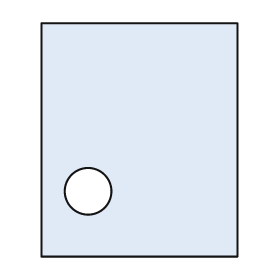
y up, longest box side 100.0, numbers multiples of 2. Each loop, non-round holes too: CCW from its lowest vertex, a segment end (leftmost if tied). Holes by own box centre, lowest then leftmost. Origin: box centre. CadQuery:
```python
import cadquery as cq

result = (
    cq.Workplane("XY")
    .moveTo(-42.0, -50.0)
    .lineTo(42.0, -50.0)
    .lineTo(42.0, 50.0)
    .lineTo(-42.0, 50.0)
    .close()
    .moveTo(-22.0, -22.0)
    .circle(10.0)
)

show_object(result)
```